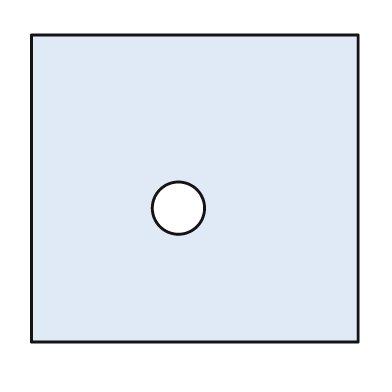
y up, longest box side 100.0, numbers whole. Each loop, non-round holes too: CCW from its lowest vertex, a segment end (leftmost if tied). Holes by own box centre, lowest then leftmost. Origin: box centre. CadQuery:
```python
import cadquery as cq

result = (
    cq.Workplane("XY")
    .moveTo(-50.0, -47.0)
    .lineTo(50.0, -47.0)
    .lineTo(50.0, 47.0)
    .lineTo(-50.0, 47.0)
    .close()
    .moveTo(-5.0, -6.0)
    .circle(8.0)
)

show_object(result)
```